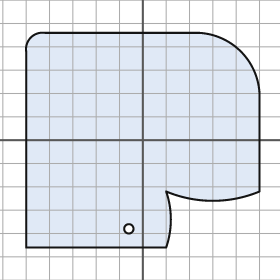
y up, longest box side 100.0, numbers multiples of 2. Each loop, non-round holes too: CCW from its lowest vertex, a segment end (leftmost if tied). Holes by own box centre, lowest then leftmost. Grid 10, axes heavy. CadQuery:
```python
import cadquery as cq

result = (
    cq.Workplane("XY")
    .moveTo(-50.0, -46.0)
    .lineTo(10.0, -46.0)
    .threePointArc((12.0, -34.0), (10.0, -22.0))
    .threePointArc((30.0, -26.0), (50.0, -22.0))
    .lineTo(50.0, 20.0)
    .threePointArc((42.0, 38.0), (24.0, 46.0))
    .lineTo(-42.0, 46.0)
    .threePointArc((-48.0, 44.0), (-50.0, 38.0))
    .close()
    .moveTo(-6.0, -38.0)
    .circle(2.0)
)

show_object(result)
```